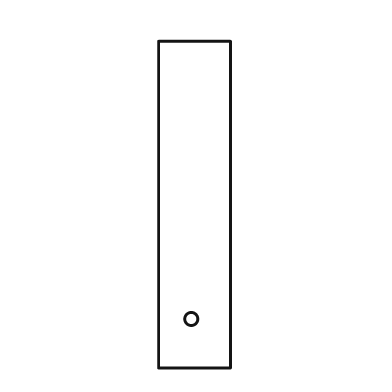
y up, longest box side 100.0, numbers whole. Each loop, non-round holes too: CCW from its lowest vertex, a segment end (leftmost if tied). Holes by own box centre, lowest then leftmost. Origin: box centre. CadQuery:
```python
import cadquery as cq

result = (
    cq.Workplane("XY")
    .moveTo(-11.0, -50.0)
    .lineTo(11.0, -50.0)
    .lineTo(11.0, 50.0)
    .lineTo(-11.0, 50.0)
    .close()
    .moveTo(-1.0, -35.0)
    .circle(2.0)
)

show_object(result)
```